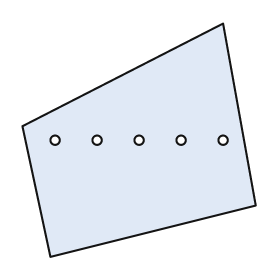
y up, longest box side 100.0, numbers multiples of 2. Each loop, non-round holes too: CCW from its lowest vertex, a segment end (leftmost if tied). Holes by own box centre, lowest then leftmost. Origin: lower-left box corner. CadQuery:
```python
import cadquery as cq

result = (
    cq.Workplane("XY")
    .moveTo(12.0, 0.0)
    .lineTo(100.0, 22.0)
    .lineTo(86.0, 100.0)
    .lineTo(0.0, 56.0)
    .close()
    .moveTo(14.0, 50.0)
    .circle(2.0)
    .moveTo(32.0, 50.0)
    .circle(2.0)
    .moveTo(50.0, 50.0)
    .circle(2.0)
    .moveTo(68.0, 50.0)
    .circle(2.0)
    .moveTo(86.0, 50.0)
    .circle(2.0)
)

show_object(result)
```